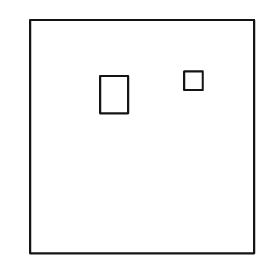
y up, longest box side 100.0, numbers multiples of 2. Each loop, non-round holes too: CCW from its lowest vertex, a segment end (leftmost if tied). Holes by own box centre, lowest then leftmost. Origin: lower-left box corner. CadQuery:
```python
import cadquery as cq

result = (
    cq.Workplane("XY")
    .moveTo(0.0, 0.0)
    .lineTo(96.0, 0.0)
    .lineTo(96.0, 100.0)
    .lineTo(0.0, 100.0)
    .close()
    .moveTo(30.0, 60.0)
    .lineTo(42.0, 60.0)
    .lineTo(42.0, 76.0)
    .lineTo(30.0, 76.0)
    .close()
    .moveTo(66.0, 70.0)
    .lineTo(74.0, 70.0)
    .lineTo(74.0, 78.0)
    .lineTo(66.0, 78.0)
    .close()
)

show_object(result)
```